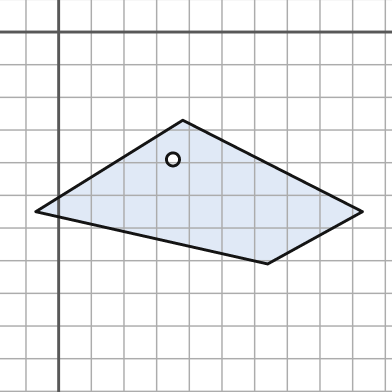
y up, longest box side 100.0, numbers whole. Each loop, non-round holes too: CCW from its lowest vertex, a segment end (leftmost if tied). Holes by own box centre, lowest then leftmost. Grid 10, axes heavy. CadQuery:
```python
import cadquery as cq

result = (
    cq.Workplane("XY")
    .moveTo(64.0, -71.0)
    .lineTo(93.0, -55.0)
    .lineTo(38.0, -27.0)
    .lineTo(-7.0, -55.0)
    .close()
    .moveTo(35.0, -39.0)
    .circle(2.0)
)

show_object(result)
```